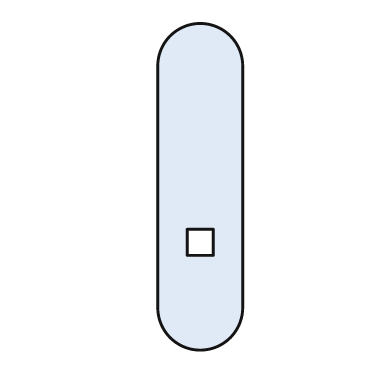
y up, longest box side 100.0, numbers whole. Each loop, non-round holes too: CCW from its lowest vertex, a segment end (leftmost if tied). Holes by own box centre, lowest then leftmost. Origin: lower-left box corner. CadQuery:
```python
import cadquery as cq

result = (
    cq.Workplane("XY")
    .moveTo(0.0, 13.0)
    .threePointArc((13.0, 0.0), (26.0, 13.0))
    .lineTo(26.0, 87.0)
    .threePointArc((13.0, 100.0), (0.0, 87.0))
    .close()
    .moveTo(9.0, 29.0)
    .lineTo(17.0, 29.0)
    .lineTo(17.0, 37.0)
    .lineTo(9.0, 37.0)
    .close()
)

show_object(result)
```